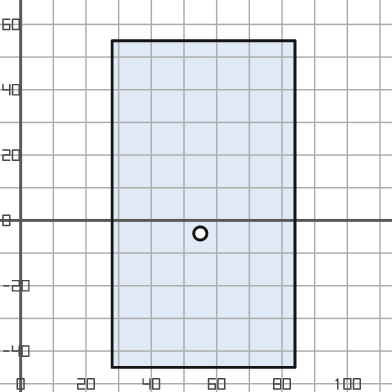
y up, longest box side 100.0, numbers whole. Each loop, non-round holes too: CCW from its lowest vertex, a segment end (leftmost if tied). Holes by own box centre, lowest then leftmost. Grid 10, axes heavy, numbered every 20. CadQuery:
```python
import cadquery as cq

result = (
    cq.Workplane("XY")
    .moveTo(28.0, -45.0)
    .lineTo(84.0, -45.0)
    .lineTo(84.0, 55.0)
    .lineTo(28.0, 55.0)
    .close()
    .moveTo(55.0, -4.0)
    .circle(2.0)
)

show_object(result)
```